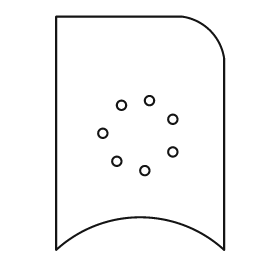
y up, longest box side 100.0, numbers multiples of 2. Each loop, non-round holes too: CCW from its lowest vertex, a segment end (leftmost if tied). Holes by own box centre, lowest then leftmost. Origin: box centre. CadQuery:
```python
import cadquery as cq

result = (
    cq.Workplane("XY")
    .moveTo(-36.0, -50.0)
    .threePointArc((0.0, -36.0), (36.0, -50.0))
    .lineTo(36.0, 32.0)
    .threePointArc((30.0, 44.0), (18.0, 50.0))
    .lineTo(-36.0, 50.0)
    .close()
    .moveTo(2.0, -16.0)
    .circle(2.0)
    .moveTo(-10.0, -12.0)
    .circle(2.0)
    .moveTo(14.0, -8.0)
    .circle(2.0)
    .moveTo(-16.0, 0.0)
    .circle(2.0)
    .moveTo(14.0, 6.0)
    .circle(2.0)
    .moveTo(-8.0, 12.0)
    .circle(2.0)
    .moveTo(4.0, 14.0)
    .circle(2.0)
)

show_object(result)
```